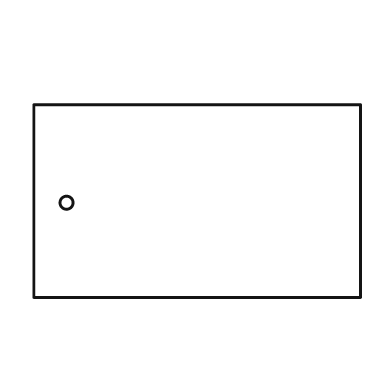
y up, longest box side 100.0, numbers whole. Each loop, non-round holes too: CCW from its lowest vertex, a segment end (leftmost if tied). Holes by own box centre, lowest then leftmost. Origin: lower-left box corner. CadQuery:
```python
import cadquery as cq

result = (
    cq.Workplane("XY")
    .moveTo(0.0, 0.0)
    .lineTo(100.0, 0.0)
    .lineTo(100.0, 59.0)
    .lineTo(0.0, 59.0)
    .close()
    .moveTo(10.0, 29.0)
    .circle(2.0)
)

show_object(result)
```